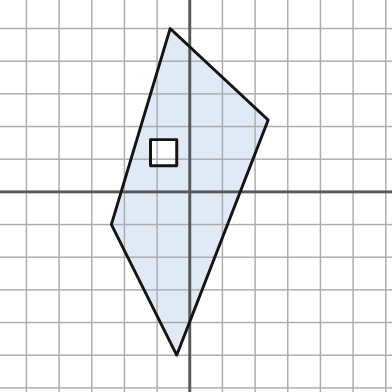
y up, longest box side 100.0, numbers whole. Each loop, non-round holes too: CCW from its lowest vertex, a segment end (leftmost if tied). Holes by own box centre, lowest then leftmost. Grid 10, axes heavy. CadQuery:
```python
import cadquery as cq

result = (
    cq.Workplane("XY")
    .moveTo(-4.0, -50.0)
    .lineTo(24.0, 22.0)
    .lineTo(-6.0, 50.0)
    .lineTo(-24.0, -10.0)
    .close()
    .moveTo(-12.0, 8.0)
    .lineTo(-4.0, 8.0)
    .lineTo(-4.0, 16.0)
    .lineTo(-12.0, 16.0)
    .close()
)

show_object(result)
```